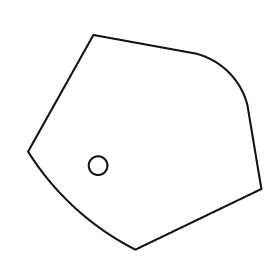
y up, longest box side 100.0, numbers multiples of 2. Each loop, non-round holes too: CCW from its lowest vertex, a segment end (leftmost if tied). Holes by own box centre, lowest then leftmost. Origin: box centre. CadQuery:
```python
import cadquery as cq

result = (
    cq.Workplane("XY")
    .moveTo(-4.0, -46.0)
    .lineTo(50.0, -20.0)
    .lineTo(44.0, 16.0)
    .threePointArc((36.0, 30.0), (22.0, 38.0))
    .lineTo(-22.0, 46.0)
    .lineTo(-50.0, -4.0)
    .threePointArc((-30.0, -28.0), (-4.0, -46.0))
    .close()
    .moveTo(-20.0, -10.0)
    .circle(4.0)
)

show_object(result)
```